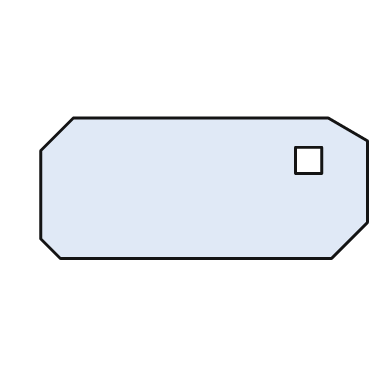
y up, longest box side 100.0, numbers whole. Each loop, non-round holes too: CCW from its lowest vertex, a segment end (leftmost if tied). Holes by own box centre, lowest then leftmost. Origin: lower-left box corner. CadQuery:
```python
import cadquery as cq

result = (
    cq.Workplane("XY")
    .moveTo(6.0, 0.0)
    .lineTo(89.0, 0.0)
    .lineTo(100.0, 11.0)
    .lineTo(100.0, 36.0)
    .lineTo(88.0, 43.0)
    .lineTo(10.0, 43.0)
    .lineTo(0.0, 33.0)
    .lineTo(0.0, 6.0)
    .close()
    .moveTo(78.0, 26.0)
    .lineTo(86.0, 26.0)
    .lineTo(86.0, 34.0)
    .lineTo(78.0, 34.0)
    .close()
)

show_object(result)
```